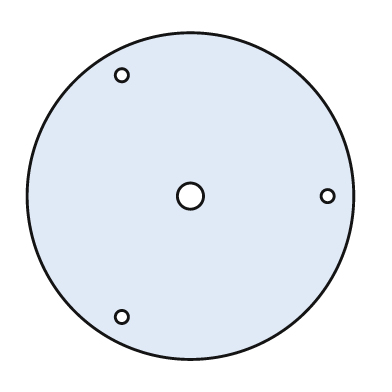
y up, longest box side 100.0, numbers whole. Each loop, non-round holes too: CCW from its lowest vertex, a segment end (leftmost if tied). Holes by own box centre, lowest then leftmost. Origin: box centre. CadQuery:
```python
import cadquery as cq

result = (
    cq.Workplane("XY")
    .moveTo(0.0, 0.0)
    .circle(50.0)
    .moveTo(-21.0, -37.0)
    .circle(2.0)
    .moveTo(0.0, 0.0)
    .circle(4.0)
    .moveTo(42.0, 0.0)
    .circle(2.0)
    .moveTo(-21.0, 37.0)
    .circle(2.0)
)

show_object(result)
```